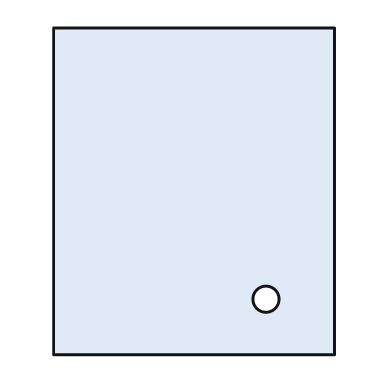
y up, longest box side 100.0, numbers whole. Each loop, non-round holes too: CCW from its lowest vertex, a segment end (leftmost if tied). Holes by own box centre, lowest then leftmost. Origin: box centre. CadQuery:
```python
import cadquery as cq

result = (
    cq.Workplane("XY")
    .moveTo(-43.0, -50.0)
    .lineTo(43.0, -50.0)
    .lineTo(43.0, 50.0)
    .lineTo(-43.0, 50.0)
    .close()
    .moveTo(22.0, -33.0)
    .circle(4.0)
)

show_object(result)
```